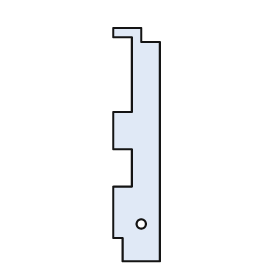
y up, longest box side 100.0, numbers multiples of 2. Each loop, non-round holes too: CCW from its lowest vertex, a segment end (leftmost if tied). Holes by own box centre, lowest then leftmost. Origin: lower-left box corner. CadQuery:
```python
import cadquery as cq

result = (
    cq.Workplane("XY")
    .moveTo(4.0, 0.0)
    .lineTo(20.0, 0.0)
    .lineTo(20.0, 94.0)
    .lineTo(12.0, 94.0)
    .lineTo(12.0, 100.0)
    .lineTo(0.0, 100.0)
    .lineTo(0.0, 96.0)
    .lineTo(8.0, 96.0)
    .lineTo(8.0, 64.0)
    .lineTo(0.0, 64.0)
    .lineTo(0.0, 48.0)
    .lineTo(8.0, 48.0)
    .lineTo(8.0, 32.0)
    .lineTo(0.0, 32.0)
    .lineTo(0.0, 10.0)
    .lineTo(4.0, 10.0)
    .close()
    .moveTo(12.0, 16.0)
    .circle(2.0)
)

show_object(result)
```